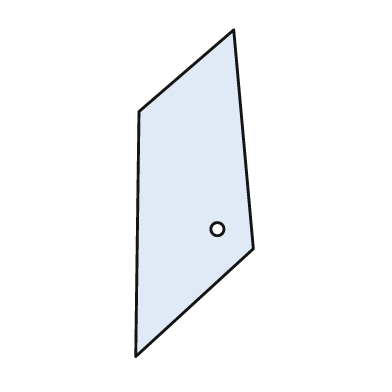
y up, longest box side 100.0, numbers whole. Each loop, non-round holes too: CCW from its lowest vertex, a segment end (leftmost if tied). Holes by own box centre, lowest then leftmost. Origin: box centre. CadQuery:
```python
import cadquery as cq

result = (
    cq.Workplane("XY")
    .moveTo(-18.0, -50.0)
    .lineTo(18.0, -17.0)
    .lineTo(12.0, 50.0)
    .lineTo(-17.0, 25.0)
    .close()
    .moveTo(7.0, -11.0)
    .circle(2.0)
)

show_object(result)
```